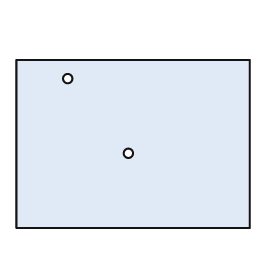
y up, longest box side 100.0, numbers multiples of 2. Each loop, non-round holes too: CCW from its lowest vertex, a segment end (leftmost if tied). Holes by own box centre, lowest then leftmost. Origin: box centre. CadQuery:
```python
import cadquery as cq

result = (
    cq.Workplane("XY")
    .moveTo(-50.0, -36.0)
    .lineTo(50.0, -36.0)
    .lineTo(50.0, 36.0)
    .lineTo(-50.0, 36.0)
    .close()
    .moveTo(-2.0, -4.0)
    .circle(2.0)
    .moveTo(-28.0, 28.0)
    .circle(2.0)
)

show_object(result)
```